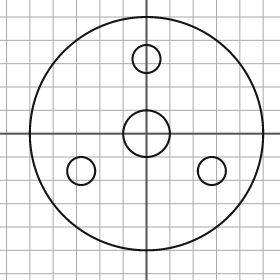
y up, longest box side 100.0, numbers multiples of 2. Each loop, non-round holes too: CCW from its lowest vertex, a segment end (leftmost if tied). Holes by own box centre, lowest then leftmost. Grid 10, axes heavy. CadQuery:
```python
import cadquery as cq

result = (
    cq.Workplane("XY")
    .moveTo(0.0, 0.0)
    .circle(50.0)
    .moveTo(-28.0, -16.0)
    .circle(6.0)
    .moveTo(28.0, -16.0)
    .circle(6.0)
    .moveTo(0.0, 0.0)
    .circle(10.0)
    .moveTo(0.0, 32.0)
    .circle(6.0)
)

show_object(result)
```